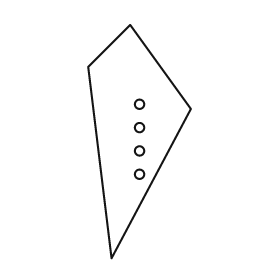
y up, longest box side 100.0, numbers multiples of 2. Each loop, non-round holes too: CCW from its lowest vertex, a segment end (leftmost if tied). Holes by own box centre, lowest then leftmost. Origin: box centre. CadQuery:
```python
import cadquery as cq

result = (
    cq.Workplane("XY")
    .moveTo(-12.0, -50.0)
    .lineTo(22.0, 14.0)
    .lineTo(-4.0, 50.0)
    .lineTo(-22.0, 32.0)
    .close()
    .moveTo(0.0, -14.0)
    .circle(2.0)
    .moveTo(0.0, -4.0)
    .circle(2.0)
    .moveTo(0.0, 6.0)
    .circle(2.0)
    .moveTo(0.0, 16.0)
    .circle(2.0)
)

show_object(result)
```